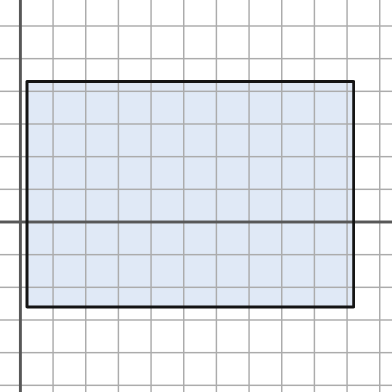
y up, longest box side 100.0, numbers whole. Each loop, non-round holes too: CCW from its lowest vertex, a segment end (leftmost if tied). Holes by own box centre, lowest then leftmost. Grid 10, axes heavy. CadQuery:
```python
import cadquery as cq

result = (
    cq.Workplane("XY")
    .moveTo(2.0, -26.0)
    .lineTo(102.0, -26.0)
    .lineTo(102.0, 43.0)
    .lineTo(2.0, 43.0)
    .close()
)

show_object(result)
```